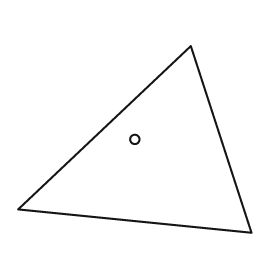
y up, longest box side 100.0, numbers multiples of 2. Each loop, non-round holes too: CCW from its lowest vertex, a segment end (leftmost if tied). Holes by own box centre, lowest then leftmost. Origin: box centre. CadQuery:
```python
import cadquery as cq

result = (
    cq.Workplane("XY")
    .moveTo(50.0, -40.0)
    .lineTo(24.0, 40.0)
    .lineTo(-50.0, -30.0)
    .close()
    .moveTo(0.0, 0.0)
    .circle(2.0)
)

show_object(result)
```